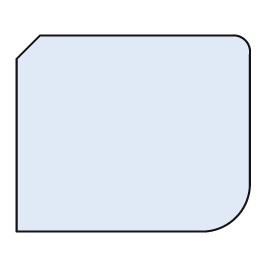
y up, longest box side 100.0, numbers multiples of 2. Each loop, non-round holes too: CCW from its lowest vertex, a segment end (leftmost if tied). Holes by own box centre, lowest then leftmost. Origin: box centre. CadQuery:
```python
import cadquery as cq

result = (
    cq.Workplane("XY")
    .moveTo(-50.0, -42.0)
    .lineTo(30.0, -42.0)
    .threePointArc((44.0, -36.0), (50.0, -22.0))
    .lineTo(50.0, 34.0)
    .threePointArc((48.0, 40.0), (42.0, 42.0))
    .lineTo(-40.0, 42.0)
    .lineTo(-50.0, 32.0)
    .close()
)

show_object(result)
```